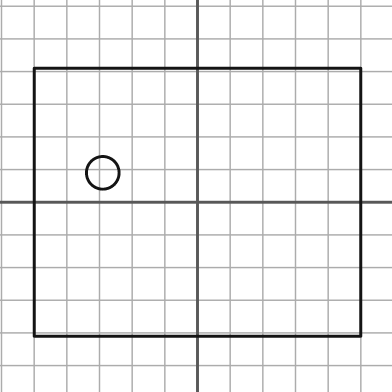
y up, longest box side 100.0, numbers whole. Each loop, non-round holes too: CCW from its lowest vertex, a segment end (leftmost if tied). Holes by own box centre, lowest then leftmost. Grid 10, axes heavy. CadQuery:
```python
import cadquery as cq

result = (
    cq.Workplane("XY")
    .moveTo(-50.0, -41.0)
    .lineTo(50.0, -41.0)
    .lineTo(50.0, 41.0)
    .lineTo(-50.0, 41.0)
    .close()
    .moveTo(-29.0, 9.0)
    .circle(5.0)
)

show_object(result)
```